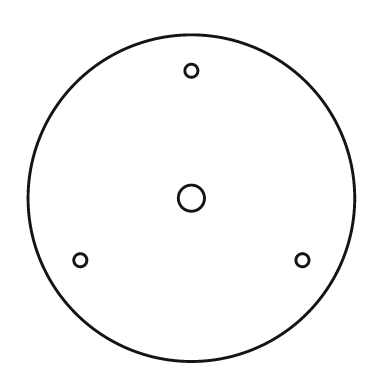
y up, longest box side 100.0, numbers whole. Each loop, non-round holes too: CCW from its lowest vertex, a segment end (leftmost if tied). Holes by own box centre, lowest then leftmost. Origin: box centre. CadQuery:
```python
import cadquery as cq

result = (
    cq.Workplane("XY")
    .moveTo(0.0, 0.0)
    .circle(50.0)
    .moveTo(-34.0, -19.0)
    .circle(2.0)
    .moveTo(34.0, -19.0)
    .circle(2.0)
    .moveTo(0.0, 0.0)
    .circle(4.0)
    .moveTo(0.0, 39.0)
    .circle(2.0)
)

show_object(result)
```